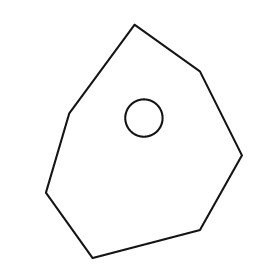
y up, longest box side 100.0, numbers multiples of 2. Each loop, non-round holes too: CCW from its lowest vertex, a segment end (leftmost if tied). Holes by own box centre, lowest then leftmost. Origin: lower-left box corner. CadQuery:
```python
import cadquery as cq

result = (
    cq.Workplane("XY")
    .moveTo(20.0, 0.0)
    .lineTo(66.0, 12.0)
    .lineTo(84.0, 44.0)
    .lineTo(66.0, 80.0)
    .lineTo(38.0, 100.0)
    .lineTo(10.0, 62.0)
    .lineTo(0.0, 28.0)
    .close()
    .moveTo(42.0, 60.0)
    .circle(8.0)
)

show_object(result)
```